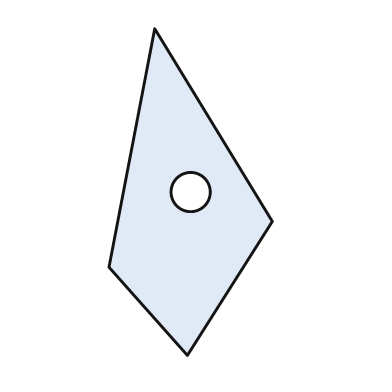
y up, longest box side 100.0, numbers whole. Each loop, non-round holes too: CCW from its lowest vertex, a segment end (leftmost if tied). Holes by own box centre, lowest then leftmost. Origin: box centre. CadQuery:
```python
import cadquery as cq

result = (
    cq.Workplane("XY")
    .moveTo(-1.0, -50.0)
    .lineTo(25.0, -9.0)
    .lineTo(-11.0, 50.0)
    .lineTo(-25.0, -23.0)
    .close()
    .moveTo(0.0, 0.0)
    .circle(6.0)
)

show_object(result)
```